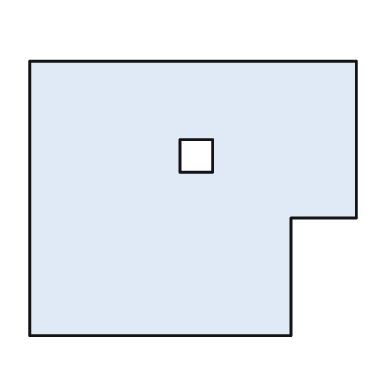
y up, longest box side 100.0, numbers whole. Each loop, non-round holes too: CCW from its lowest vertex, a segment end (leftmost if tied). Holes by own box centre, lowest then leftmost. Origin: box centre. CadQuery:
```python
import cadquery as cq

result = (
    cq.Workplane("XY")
    .moveTo(-50.0, -42.0)
    .lineTo(30.0, -42.0)
    .lineTo(30.0, -6.0)
    .lineTo(50.0, -6.0)
    .lineTo(50.0, 42.0)
    .lineTo(-50.0, 42.0)
    .close()
    .moveTo(-4.0, 8.0)
    .lineTo(6.0, 8.0)
    .lineTo(6.0, 18.0)
    .lineTo(-4.0, 18.0)
    .close()
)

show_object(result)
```